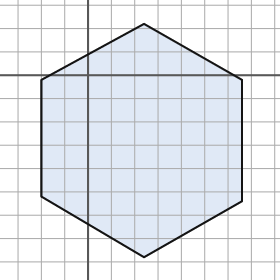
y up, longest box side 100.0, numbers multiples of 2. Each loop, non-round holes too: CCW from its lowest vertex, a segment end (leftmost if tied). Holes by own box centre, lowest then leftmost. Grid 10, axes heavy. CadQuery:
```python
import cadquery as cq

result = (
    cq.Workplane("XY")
    .moveTo(24.0, -78.0)
    .lineTo(66.0, -54.0)
    .lineTo(66.0, -2.0)
    .lineTo(24.0, 22.0)
    .lineTo(-20.0, -2.0)
    .lineTo(-20.0, -52.0)
    .close()
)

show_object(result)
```